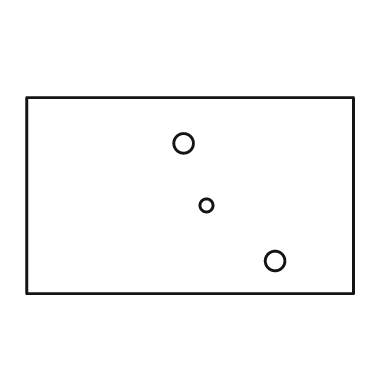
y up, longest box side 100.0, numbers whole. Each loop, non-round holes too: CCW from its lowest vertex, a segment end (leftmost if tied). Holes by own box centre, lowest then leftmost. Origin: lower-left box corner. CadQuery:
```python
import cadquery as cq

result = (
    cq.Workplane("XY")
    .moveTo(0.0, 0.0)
    .lineTo(100.0, 0.0)
    .lineTo(100.0, 60.0)
    .lineTo(0.0, 60.0)
    .close()
    .moveTo(76.0, 10.0)
    .circle(3.0)
    .moveTo(55.0, 27.0)
    .circle(2.0)
    .moveTo(48.0, 46.0)
    .circle(3.0)
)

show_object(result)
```